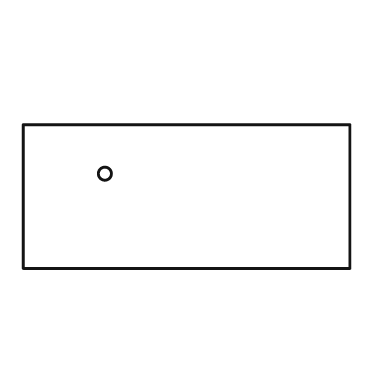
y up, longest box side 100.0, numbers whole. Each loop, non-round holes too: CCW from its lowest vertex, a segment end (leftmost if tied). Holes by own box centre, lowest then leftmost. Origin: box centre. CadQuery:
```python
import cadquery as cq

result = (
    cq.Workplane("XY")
    .moveTo(-50.0, -22.0)
    .lineTo(50.0, -22.0)
    .lineTo(50.0, 22.0)
    .lineTo(-50.0, 22.0)
    .close()
    .moveTo(-25.0, 7.0)
    .circle(2.0)
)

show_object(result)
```